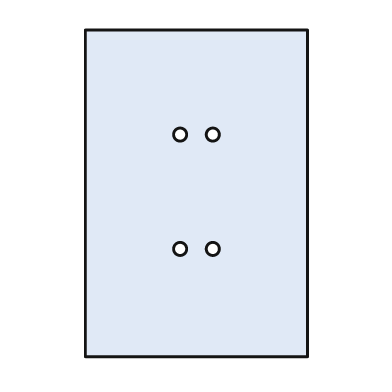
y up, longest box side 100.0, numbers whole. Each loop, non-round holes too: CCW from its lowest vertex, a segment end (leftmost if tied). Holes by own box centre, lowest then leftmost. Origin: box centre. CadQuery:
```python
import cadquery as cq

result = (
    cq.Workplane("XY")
    .moveTo(-34.0, -50.0)
    .lineTo(34.0, -50.0)
    .lineTo(34.0, 50.0)
    .lineTo(-34.0, 50.0)
    .close()
    .moveTo(-5.0, -17.0)
    .circle(2.0)
    .moveTo(5.0, -17.0)
    .circle(2.0)
    .moveTo(-5.0, 18.0)
    .circle(2.0)
    .moveTo(5.0, 18.0)
    .circle(2.0)
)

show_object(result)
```